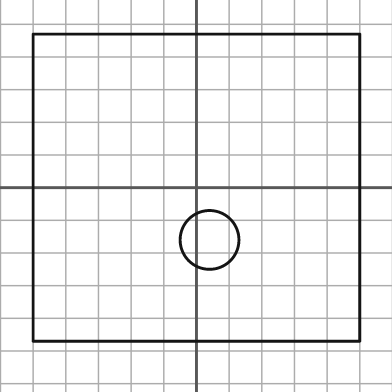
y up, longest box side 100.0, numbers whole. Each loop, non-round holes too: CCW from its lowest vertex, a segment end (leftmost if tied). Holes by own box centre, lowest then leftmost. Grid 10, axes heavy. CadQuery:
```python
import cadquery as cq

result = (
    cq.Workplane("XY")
    .moveTo(-50.0, -47.0)
    .lineTo(50.0, -47.0)
    .lineTo(50.0, 47.0)
    .lineTo(-50.0, 47.0)
    .close()
    .moveTo(4.0, -16.0)
    .circle(9.0)
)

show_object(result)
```